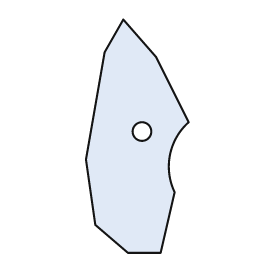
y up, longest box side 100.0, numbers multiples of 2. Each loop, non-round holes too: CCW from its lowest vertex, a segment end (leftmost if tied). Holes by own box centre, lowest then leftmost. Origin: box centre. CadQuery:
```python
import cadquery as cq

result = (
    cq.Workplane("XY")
    .moveTo(-4.0, -50.0)
    .lineTo(10.0, -50.0)
    .lineTo(16.0, -24.0)
    .threePointArc((14.0, -8.0), (22.0, 6.0))
    .lineTo(8.0, 34.0)
    .lineTo(-6.0, 50.0)
    .lineTo(-14.0, 36.0)
    .lineTo(-22.0, -10.0)
    .lineTo(-18.0, -38.0)
    .close()
    .moveTo(2.0, 2.0)
    .circle(4.0)
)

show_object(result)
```